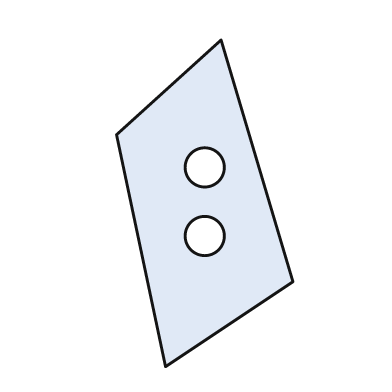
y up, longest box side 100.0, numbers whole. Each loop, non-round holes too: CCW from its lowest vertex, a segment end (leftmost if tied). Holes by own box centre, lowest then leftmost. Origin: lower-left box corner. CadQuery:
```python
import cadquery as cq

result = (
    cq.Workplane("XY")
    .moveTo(15.0, 0.0)
    .lineTo(54.0, 26.0)
    .lineTo(32.0, 100.0)
    .lineTo(0.0, 71.0)
    .close()
    .moveTo(27.0, 40.0)
    .circle(6.0)
    .moveTo(27.0, 61.0)
    .circle(6.0)
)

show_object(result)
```